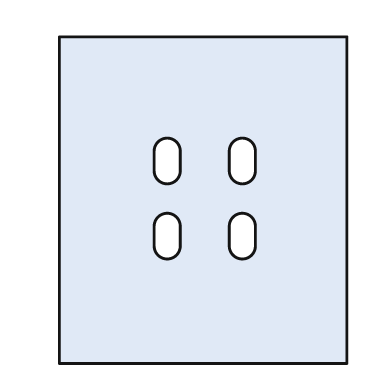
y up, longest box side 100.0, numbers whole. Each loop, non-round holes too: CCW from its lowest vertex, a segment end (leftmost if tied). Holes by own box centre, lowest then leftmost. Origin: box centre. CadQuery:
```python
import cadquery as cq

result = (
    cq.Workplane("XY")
    .moveTo(-44.0, -50.0)
    .lineTo(44.0, -50.0)
    .lineTo(44.0, 50.0)
    .lineTo(-44.0, 50.0)
    .close()
    .moveTo(-15.0, -14.0)
    .threePointArc((-11.0, -18.0), (-7.0, -14.0))
    .lineTo(-7.0, -8.0)
    .threePointArc((-11.0, -4.0), (-15.0, -8.0))
    .close()
    .moveTo(8.0, -14.0)
    .threePointArc((12.0, -18.0), (16.0, -14.0))
    .lineTo(16.0, -8.0)
    .threePointArc((12.0, -4.0), (8.0, -8.0))
    .close()
    .moveTo(-15.0, 9.0)
    .threePointArc((-11.0, 5.0), (-7.0, 9.0))
    .lineTo(-7.0, 15.0)
    .threePointArc((-11.0, 19.0), (-15.0, 15.0))
    .close()
    .moveTo(8.0, 9.0)
    .threePointArc((12.0, 5.0), (16.0, 9.0))
    .lineTo(16.0, 15.0)
    .threePointArc((12.0, 19.0), (8.0, 15.0))
    .close()
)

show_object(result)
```